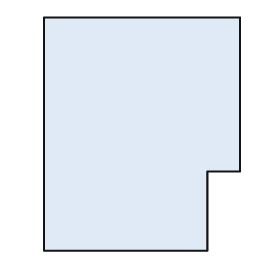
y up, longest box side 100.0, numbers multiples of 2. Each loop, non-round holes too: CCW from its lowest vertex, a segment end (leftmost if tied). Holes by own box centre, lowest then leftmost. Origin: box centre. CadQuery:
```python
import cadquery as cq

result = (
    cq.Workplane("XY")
    .moveTo(-42.0, -50.0)
    .lineTo(28.0, -50.0)
    .lineTo(28.0, -16.0)
    .lineTo(42.0, -16.0)
    .lineTo(42.0, 50.0)
    .lineTo(-42.0, 50.0)
    .close()
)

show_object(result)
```